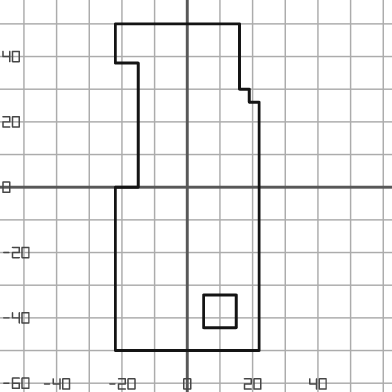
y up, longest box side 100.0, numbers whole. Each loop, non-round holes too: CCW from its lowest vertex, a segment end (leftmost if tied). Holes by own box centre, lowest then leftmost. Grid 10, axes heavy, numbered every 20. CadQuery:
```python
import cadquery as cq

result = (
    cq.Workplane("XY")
    .moveTo(-22.0, -50.0)
    .lineTo(22.0, -50.0)
    .lineTo(22.0, 26.0)
    .lineTo(19.0, 26.0)
    .lineTo(19.0, 30.0)
    .lineTo(16.0, 30.0)
    .lineTo(16.0, 50.0)
    .lineTo(-22.0, 50.0)
    .lineTo(-22.0, 38.0)
    .lineTo(-15.0, 38.0)
    .lineTo(-15.0, 0.0)
    .lineTo(-22.0, 0.0)
    .close()
    .moveTo(5.0, -43.0)
    .lineTo(15.0, -43.0)
    .lineTo(15.0, -33.0)
    .lineTo(5.0, -33.0)
    .close()
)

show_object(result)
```